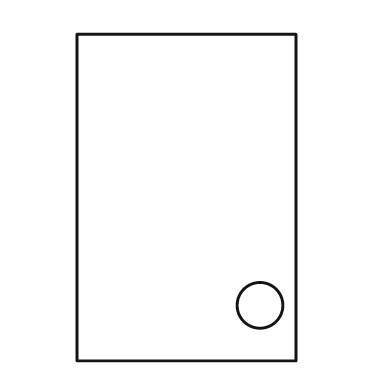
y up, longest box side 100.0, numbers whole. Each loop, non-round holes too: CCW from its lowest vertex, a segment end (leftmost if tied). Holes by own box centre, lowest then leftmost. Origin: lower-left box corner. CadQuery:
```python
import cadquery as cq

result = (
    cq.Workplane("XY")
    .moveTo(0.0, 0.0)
    .lineTo(67.0, 0.0)
    .lineTo(67.0, 100.0)
    .lineTo(0.0, 100.0)
    .close()
    .moveTo(56.0, 17.0)
    .circle(7.0)
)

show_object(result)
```